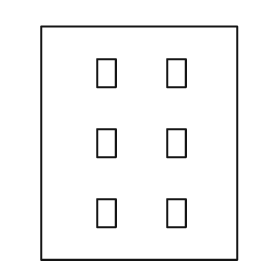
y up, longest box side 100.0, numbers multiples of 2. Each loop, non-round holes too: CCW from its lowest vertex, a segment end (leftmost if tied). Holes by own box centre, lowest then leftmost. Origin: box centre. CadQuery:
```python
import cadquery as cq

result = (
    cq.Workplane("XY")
    .moveTo(-42.0, -50.0)
    .lineTo(42.0, -50.0)
    .lineTo(42.0, 50.0)
    .lineTo(-42.0, 50.0)
    .close()
    .moveTo(-18.0, -36.0)
    .lineTo(-10.0, -36.0)
    .lineTo(-10.0, -24.0)
    .lineTo(-18.0, -24.0)
    .close()
    .moveTo(12.0, -36.0)
    .lineTo(20.0, -36.0)
    .lineTo(20.0, -24.0)
    .lineTo(12.0, -24.0)
    .close()
    .moveTo(-18.0, -6.0)
    .lineTo(-10.0, -6.0)
    .lineTo(-10.0, 6.0)
    .lineTo(-18.0, 6.0)
    .close()
    .moveTo(12.0, -6.0)
    .lineTo(20.0, -6.0)
    .lineTo(20.0, 6.0)
    .lineTo(12.0, 6.0)
    .close()
    .moveTo(-18.0, 24.0)
    .lineTo(-10.0, 24.0)
    .lineTo(-10.0, 36.0)
    .lineTo(-18.0, 36.0)
    .close()
    .moveTo(12.0, 24.0)
    .lineTo(20.0, 24.0)
    .lineTo(20.0, 36.0)
    .lineTo(12.0, 36.0)
    .close()
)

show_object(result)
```